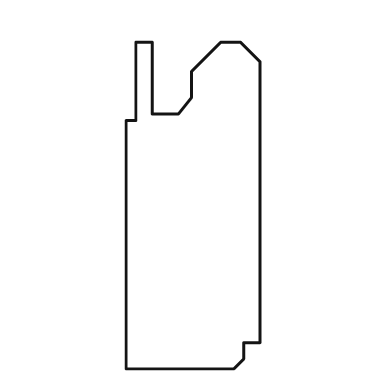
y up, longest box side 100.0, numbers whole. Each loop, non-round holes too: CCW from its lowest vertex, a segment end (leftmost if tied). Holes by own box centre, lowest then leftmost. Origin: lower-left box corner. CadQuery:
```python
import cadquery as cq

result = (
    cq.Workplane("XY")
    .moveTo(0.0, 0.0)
    .lineTo(33.0, 0.0)
    .lineTo(36.0, 3.0)
    .lineTo(36.0, 8.0)
    .lineTo(41.0, 8.0)
    .lineTo(41.0, 94.0)
    .lineTo(35.0, 100.0)
    .lineTo(29.0, 100.0)
    .lineTo(20.0, 91.0)
    .lineTo(20.0, 83.0)
    .lineTo(16.0, 78.0)
    .lineTo(8.0, 78.0)
    .lineTo(8.0, 100.0)
    .lineTo(3.0, 100.0)
    .lineTo(3.0, 76.0)
    .lineTo(0.0, 76.0)
    .close()
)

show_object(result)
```